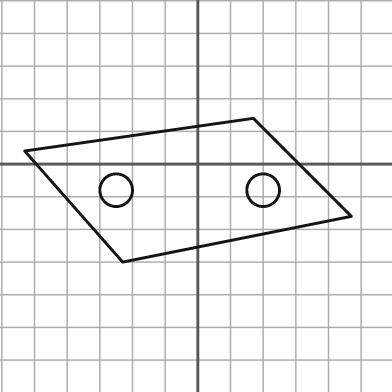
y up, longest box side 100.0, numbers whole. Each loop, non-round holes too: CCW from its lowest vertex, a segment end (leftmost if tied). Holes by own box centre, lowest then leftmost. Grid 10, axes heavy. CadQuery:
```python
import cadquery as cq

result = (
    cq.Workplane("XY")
    .moveTo(-23.0, -30.0)
    .lineTo(47.0, -16.0)
    .lineTo(17.0, 14.0)
    .lineTo(-53.0, 4.0)
    .close()
    .moveTo(-25.0, -8.0)
    .circle(5.0)
    .moveTo(20.0, -8.0)
    .circle(5.0)
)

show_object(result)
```